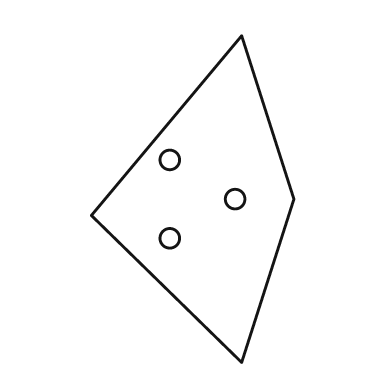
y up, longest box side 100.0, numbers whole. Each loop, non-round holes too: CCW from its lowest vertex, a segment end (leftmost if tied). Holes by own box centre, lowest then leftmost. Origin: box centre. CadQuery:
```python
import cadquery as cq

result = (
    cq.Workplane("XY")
    .moveTo(15.0, -50.0)
    .lineTo(31.0, 0.0)
    .lineTo(15.0, 50.0)
    .lineTo(-31.0, -5.0)
    .close()
    .moveTo(-7.0, -12.0)
    .circle(3.0)
    .moveTo(13.0, 0.0)
    .circle(3.0)
    .moveTo(-7.0, 12.0)
    .circle(3.0)
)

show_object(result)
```